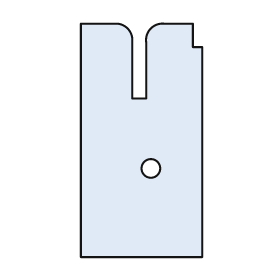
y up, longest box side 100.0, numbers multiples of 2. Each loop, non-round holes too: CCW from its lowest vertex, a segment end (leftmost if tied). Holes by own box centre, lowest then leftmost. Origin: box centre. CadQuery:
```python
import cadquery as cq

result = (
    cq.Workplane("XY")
    .moveTo(-26.0, -50.0)
    .lineTo(26.0, -50.0)
    .lineTo(26.0, 40.0)
    .lineTo(22.0, 40.0)
    .lineTo(22.0, 50.0)
    .lineTo(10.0, 50.0)
    .threePointArc((4.0, 48.0), (2.0, 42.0))
    .lineTo(2.0, 18.0)
    .lineTo(-4.0, 18.0)
    .lineTo(-4.0, 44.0)
    .threePointArc((-6.0, 48.0), (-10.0, 50.0))
    .lineTo(-26.0, 50.0)
    .close()
    .moveTo(4.0, -12.0)
    .circle(4.0)
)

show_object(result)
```